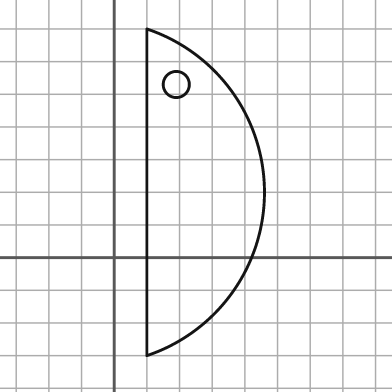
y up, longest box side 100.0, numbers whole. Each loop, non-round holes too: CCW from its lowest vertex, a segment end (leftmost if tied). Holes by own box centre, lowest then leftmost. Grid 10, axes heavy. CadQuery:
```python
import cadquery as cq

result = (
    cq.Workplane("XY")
    .moveTo(10.0, -30.0)
    .threePointArc((46.0, 20.0), (10.0, 70.0))
    .close()
    .moveTo(19.0, 53.0)
    .circle(4.0)
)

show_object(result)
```